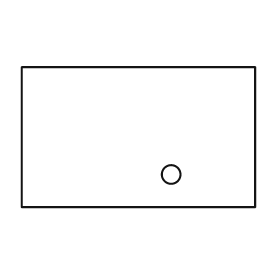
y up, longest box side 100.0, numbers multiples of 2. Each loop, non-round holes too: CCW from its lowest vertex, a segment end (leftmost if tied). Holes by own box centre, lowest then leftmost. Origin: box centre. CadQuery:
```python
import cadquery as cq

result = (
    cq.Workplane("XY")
    .moveTo(-50.0, -30.0)
    .lineTo(50.0, -30.0)
    .lineTo(50.0, 30.0)
    .lineTo(-50.0, 30.0)
    .close()
    .moveTo(14.0, -16.0)
    .circle(4.0)
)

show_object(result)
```